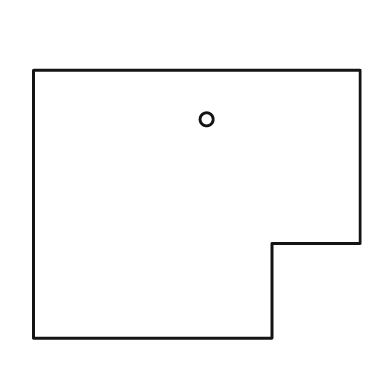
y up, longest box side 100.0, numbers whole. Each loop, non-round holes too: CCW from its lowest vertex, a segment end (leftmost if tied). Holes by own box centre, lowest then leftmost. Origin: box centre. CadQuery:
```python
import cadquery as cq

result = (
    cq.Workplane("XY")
    .moveTo(-50.0, -41.0)
    .lineTo(23.0, -41.0)
    .lineTo(23.0, -12.0)
    .lineTo(50.0, -12.0)
    .lineTo(50.0, 41.0)
    .lineTo(-50.0, 41.0)
    .close()
    .moveTo(3.0, 26.0)
    .circle(2.0)
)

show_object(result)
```